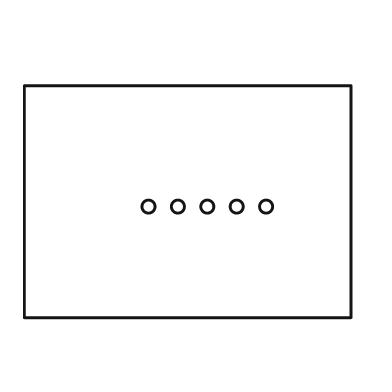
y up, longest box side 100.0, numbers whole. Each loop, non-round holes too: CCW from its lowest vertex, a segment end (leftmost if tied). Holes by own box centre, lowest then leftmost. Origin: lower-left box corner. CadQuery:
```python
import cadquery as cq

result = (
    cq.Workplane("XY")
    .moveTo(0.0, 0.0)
    .lineTo(100.0, 0.0)
    .lineTo(100.0, 71.0)
    .lineTo(0.0, 71.0)
    .close()
    .moveTo(38.0, 34.0)
    .circle(2.0)
    .moveTo(47.0, 34.0)
    .circle(2.0)
    .moveTo(56.0, 34.0)
    .circle(2.0)
    .moveTo(65.0, 34.0)
    .circle(2.0)
    .moveTo(74.0, 34.0)
    .circle(2.0)
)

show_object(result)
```